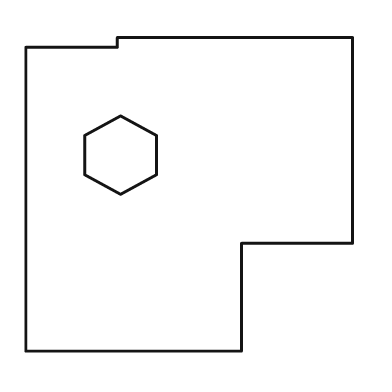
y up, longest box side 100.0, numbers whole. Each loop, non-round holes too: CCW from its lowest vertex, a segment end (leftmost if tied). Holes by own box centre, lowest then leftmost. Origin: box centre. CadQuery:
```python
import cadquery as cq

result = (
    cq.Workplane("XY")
    .moveTo(-50.0, -48.0)
    .lineTo(16.0, -48.0)
    .lineTo(16.0, -15.0)
    .lineTo(50.0, -15.0)
    .lineTo(50.0, 48.0)
    .lineTo(-22.0, 48.0)
    .lineTo(-22.0, 45.0)
    .lineTo(-50.0, 45.0)
    .close()
    .moveTo(-21.0, 0.0)
    .lineTo(-10.0, 6.0)
    .lineTo(-10.0, 18.0)
    .lineTo(-21.0, 24.0)
    .lineTo(-32.0, 18.0)
    .lineTo(-32.0, 6.0)
    .close()
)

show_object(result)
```